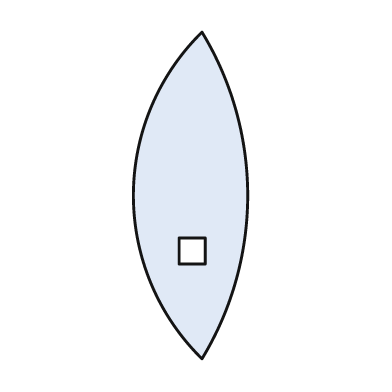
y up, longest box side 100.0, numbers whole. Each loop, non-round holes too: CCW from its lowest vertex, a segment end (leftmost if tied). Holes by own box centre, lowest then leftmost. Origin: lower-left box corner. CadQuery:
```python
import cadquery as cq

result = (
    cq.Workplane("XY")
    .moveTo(21.0, 0.0)
    .threePointArc((35.0, 50.0), (21.0, 100.0))
    .threePointArc((0.0, 50.0), (21.0, 0.0))
    .close()
    .moveTo(14.0, 29.0)
    .lineTo(22.0, 29.0)
    .lineTo(22.0, 37.0)
    .lineTo(14.0, 37.0)
    .close()
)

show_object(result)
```